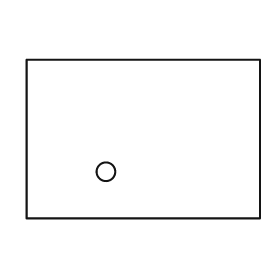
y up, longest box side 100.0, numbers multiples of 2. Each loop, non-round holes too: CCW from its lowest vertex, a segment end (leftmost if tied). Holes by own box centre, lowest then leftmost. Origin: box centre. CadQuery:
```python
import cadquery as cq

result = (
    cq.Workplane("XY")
    .moveTo(-50.0, -34.0)
    .lineTo(50.0, -34.0)
    .lineTo(50.0, 34.0)
    .lineTo(-50.0, 34.0)
    .close()
    .moveTo(-16.0, -14.0)
    .circle(4.0)
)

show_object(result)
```